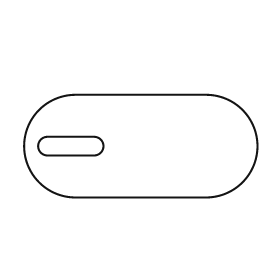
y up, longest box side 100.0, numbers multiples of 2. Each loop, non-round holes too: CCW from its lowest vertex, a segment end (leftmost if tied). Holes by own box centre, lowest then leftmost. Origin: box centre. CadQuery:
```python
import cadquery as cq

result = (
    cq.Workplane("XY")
    .moveTo(-28.0, -22.0)
    .lineTo(28.0, -22.0)
    .threePointArc((50.0, 0.0), (28.0, 22.0))
    .lineTo(-28.0, 22.0)
    .threePointArc((-50.0, 0.0), (-28.0, -22.0))
    .close()
    .moveTo(-40.0, -4.0)
    .lineTo(-20.0, -4.0)
    .threePointArc((-16.0, 0.0), (-20.0, 4.0))
    .lineTo(-40.0, 4.0)
    .threePointArc((-44.0, 0.0), (-40.0, -4.0))
    .close()
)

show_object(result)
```